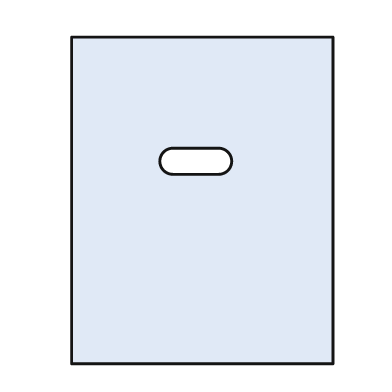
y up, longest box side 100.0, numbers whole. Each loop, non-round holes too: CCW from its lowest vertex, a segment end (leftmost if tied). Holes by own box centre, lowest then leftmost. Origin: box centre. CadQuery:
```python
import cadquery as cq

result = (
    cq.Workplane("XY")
    .moveTo(-40.0, -50.0)
    .lineTo(40.0, -50.0)
    .lineTo(40.0, 50.0)
    .lineTo(-40.0, 50.0)
    .close()
    .moveTo(-9.0, 8.0)
    .lineTo(5.0, 8.0)
    .threePointArc((9.0, 12.0), (5.0, 16.0))
    .lineTo(-9.0, 16.0)
    .threePointArc((-13.0, 12.0), (-9.0, 8.0))
    .close()
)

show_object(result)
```